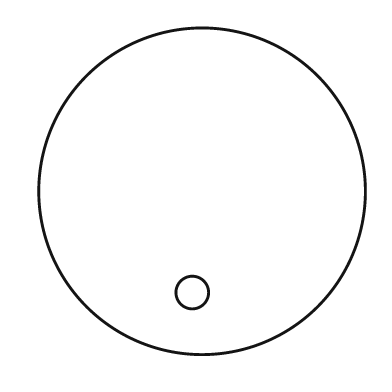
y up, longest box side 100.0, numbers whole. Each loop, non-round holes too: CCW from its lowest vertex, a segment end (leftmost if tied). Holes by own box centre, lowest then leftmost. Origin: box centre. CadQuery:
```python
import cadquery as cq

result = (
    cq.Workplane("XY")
    .moveTo(0.0, 0.0)
    .circle(50.0)
    .moveTo(-3.0, -31.0)
    .circle(5.0)
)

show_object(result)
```